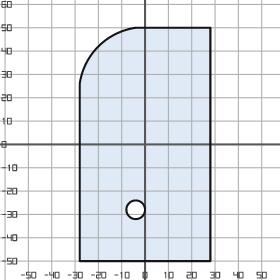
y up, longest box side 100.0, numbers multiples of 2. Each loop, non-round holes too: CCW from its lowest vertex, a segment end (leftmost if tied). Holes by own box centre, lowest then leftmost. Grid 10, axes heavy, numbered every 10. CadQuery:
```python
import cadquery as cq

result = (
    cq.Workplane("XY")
    .moveTo(-28.0, -50.0)
    .lineTo(28.0, -50.0)
    .lineTo(28.0, 50.0)
    .lineTo(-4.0, 50.0)
    .threePointArc((-20.0, 42.0), (-28.0, 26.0))
    .close()
    .moveTo(-4.0, -28.0)
    .circle(4.0)
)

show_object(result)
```